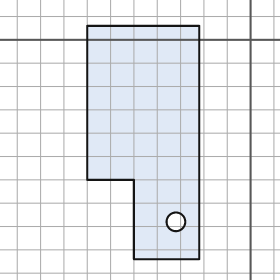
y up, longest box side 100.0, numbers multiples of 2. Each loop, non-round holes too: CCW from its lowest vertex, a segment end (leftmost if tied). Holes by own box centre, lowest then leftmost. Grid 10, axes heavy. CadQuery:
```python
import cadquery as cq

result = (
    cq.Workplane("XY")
    .moveTo(-50.0, -94.0)
    .lineTo(-22.0, -94.0)
    .lineTo(-22.0, 6.0)
    .lineTo(-70.0, 6.0)
    .lineTo(-70.0, -60.0)
    .lineTo(-50.0, -60.0)
    .close()
    .moveTo(-32.0, -78.0)
    .circle(4.0)
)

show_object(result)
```